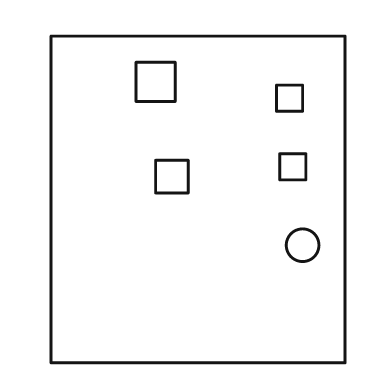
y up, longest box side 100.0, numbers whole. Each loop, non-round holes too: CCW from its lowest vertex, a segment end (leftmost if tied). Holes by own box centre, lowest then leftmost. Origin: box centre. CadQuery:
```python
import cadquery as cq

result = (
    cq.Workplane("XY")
    .moveTo(-45.0, -50.0)
    .lineTo(45.0, -50.0)
    .lineTo(45.0, 50.0)
    .lineTo(-45.0, 50.0)
    .close()
    .moveTo(32.0, -14.0)
    .circle(5.0)
    .moveTo(-13.0, 2.0)
    .lineTo(-3.0, 2.0)
    .lineTo(-3.0, 12.0)
    .lineTo(-13.0, 12.0)
    .close()
    .moveTo(25.0, 6.0)
    .lineTo(33.0, 6.0)
    .lineTo(33.0, 14.0)
    .lineTo(25.0, 14.0)
    .close()
    .moveTo(24.0, 27.0)
    .lineTo(32.0, 27.0)
    .lineTo(32.0, 35.0)
    .lineTo(24.0, 35.0)
    .close()
    .moveTo(-19.0, 30.0)
    .lineTo(-7.0, 30.0)
    .lineTo(-7.0, 42.0)
    .lineTo(-19.0, 42.0)
    .close()
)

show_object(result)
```